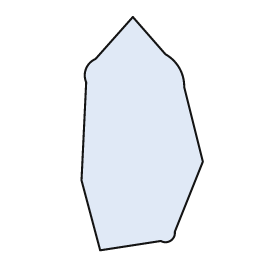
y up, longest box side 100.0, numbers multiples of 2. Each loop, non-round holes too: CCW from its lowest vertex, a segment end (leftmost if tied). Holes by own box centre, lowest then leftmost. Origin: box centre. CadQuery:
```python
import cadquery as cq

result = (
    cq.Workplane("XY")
    .moveTo(-18.0, -50.0)
    .lineTo(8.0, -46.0)
    .threePointArc((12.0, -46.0), (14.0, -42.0))
    .lineTo(26.0, -12.0)
    .lineTo(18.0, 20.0)
    .threePointArc((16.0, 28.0), (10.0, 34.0))
    .lineTo(-4.0, 50.0)
    .lineTo(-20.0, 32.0)
    .threePointArc((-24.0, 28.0), (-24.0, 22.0))
    .lineTo(-26.0, -20.0)
    .close()
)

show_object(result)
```